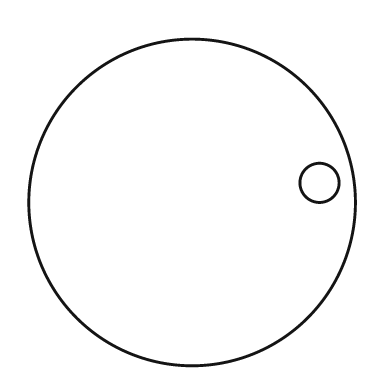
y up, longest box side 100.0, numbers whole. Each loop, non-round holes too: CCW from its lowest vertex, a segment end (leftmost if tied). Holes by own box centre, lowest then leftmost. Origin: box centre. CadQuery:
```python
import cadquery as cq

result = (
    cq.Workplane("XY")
    .moveTo(0.0, 0.0)
    .circle(50.0)
    .moveTo(39.0, 6.0)
    .circle(6.0)
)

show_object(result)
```